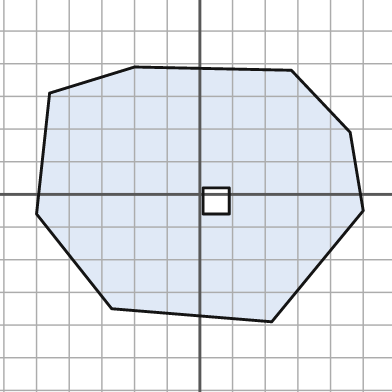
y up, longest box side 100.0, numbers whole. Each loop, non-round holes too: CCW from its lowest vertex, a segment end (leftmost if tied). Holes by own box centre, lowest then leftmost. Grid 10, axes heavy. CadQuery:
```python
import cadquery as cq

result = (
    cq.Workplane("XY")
    .moveTo(22.0, -39.0)
    .lineTo(50.0, -5.0)
    .lineTo(46.0, 19.0)
    .lineTo(28.0, 38.0)
    .lineTo(-20.0, 39.0)
    .lineTo(-46.0, 31.0)
    .lineTo(-50.0, -6.0)
    .lineTo(-27.0, -35.0)
    .close()
    .moveTo(1.0, -6.0)
    .lineTo(9.0, -6.0)
    .lineTo(9.0, 2.0)
    .lineTo(1.0, 2.0)
    .close()
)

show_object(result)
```